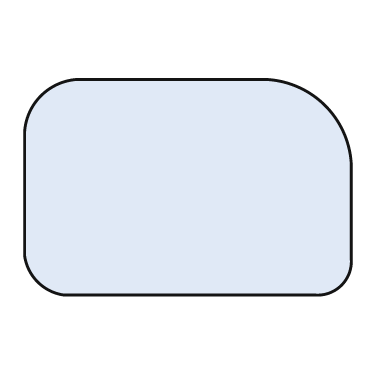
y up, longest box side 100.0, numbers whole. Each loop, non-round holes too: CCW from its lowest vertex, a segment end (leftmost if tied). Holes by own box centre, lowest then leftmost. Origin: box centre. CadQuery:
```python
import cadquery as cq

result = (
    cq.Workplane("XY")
    .moveTo(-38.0, -33.0)
    .lineTo(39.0, -33.0)
    .threePointArc((47.0, -30.0), (50.0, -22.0))
    .lineTo(50.0, 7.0)
    .threePointArc((42.0, 25.0), (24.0, 33.0))
    .lineTo(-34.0, 33.0)
    .threePointArc((-45.0, 28.0), (-50.0, 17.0))
    .lineTo(-50.0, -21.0)
    .threePointArc((-46.0, -29.0), (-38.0, -33.0))
    .close()
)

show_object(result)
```